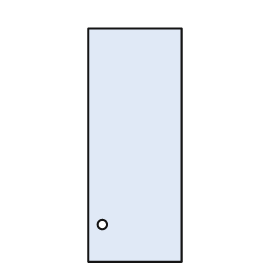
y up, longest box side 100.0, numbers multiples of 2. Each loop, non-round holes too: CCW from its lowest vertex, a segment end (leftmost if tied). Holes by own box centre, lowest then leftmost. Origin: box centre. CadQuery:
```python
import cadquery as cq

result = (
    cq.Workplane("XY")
    .moveTo(-20.0, -50.0)
    .lineTo(20.0, -50.0)
    .lineTo(20.0, 50.0)
    .lineTo(-20.0, 50.0)
    .close()
    .moveTo(-14.0, -34.0)
    .circle(2.0)
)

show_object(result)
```